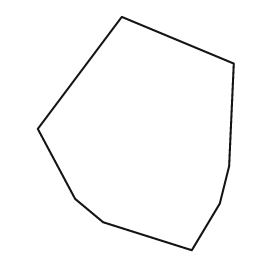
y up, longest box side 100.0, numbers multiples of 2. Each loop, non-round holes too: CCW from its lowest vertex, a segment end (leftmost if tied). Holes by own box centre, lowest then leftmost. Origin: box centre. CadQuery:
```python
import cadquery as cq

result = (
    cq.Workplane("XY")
    .moveTo(24.0, -50.0)
    .lineTo(36.0, -30.0)
    .lineTo(40.0, -14.0)
    .lineTo(42.0, 30.0)
    .lineTo(-6.0, 50.0)
    .lineTo(-42.0, 2.0)
    .lineTo(-26.0, -28.0)
    .lineTo(-14.0, -38.0)
    .close()
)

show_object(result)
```